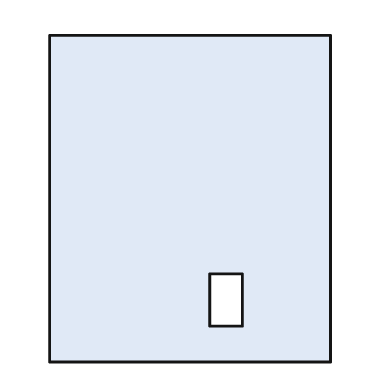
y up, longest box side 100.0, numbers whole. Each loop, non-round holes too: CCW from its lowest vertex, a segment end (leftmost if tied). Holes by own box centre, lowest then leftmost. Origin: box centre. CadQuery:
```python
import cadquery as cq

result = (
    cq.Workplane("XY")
    .moveTo(-43.0, -50.0)
    .lineTo(43.0, -50.0)
    .lineTo(43.0, 50.0)
    .lineTo(-43.0, 50.0)
    .close()
    .moveTo(6.0, -39.0)
    .lineTo(16.0, -39.0)
    .lineTo(16.0, -23.0)
    .lineTo(6.0, -23.0)
    .close()
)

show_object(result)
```